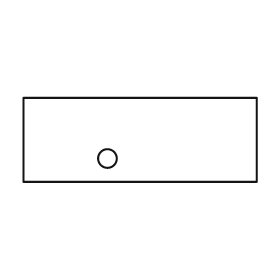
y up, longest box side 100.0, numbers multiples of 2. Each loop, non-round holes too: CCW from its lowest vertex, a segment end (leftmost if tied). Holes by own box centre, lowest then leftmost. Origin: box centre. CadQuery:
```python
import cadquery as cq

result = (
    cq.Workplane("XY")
    .moveTo(-50.0, -18.0)
    .lineTo(50.0, -18.0)
    .lineTo(50.0, 18.0)
    .lineTo(-50.0, 18.0)
    .close()
    .moveTo(-14.0, -8.0)
    .circle(4.0)
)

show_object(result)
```